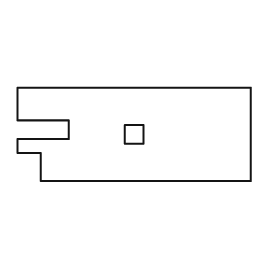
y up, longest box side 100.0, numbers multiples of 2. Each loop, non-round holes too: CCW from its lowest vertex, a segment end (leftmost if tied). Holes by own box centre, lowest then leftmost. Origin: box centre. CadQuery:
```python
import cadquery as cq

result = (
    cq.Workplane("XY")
    .moveTo(-40.0, -20.0)
    .lineTo(50.0, -20.0)
    .lineTo(50.0, 20.0)
    .lineTo(-50.0, 20.0)
    .lineTo(-50.0, 6.0)
    .lineTo(-28.0, 6.0)
    .lineTo(-28.0, -2.0)
    .lineTo(-50.0, -2.0)
    .lineTo(-50.0, -8.0)
    .lineTo(-40.0, -8.0)
    .close()
    .moveTo(-4.0, -4.0)
    .lineTo(4.0, -4.0)
    .lineTo(4.0, 4.0)
    .lineTo(-4.0, 4.0)
    .close()
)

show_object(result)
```